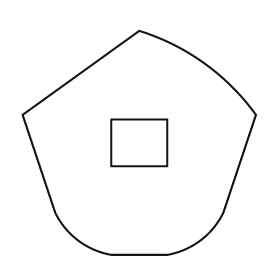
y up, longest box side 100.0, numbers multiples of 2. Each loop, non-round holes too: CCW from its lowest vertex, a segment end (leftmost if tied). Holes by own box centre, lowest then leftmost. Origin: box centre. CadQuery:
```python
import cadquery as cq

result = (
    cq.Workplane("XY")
    .moveTo(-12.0, -48.0)
    .lineTo(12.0, -48.0)
    .threePointArc((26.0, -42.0), (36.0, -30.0))
    .lineTo(50.0, 12.0)
    .threePointArc((28.0, 34.0), (0.0, 48.0))
    .lineTo(-50.0, 12.0)
    .lineTo(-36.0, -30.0)
    .threePointArc((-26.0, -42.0), (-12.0, -48.0))
    .close()
    .moveTo(-12.0, -10.0)
    .lineTo(12.0, -10.0)
    .lineTo(12.0, 10.0)
    .lineTo(-12.0, 10.0)
    .close()
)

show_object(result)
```